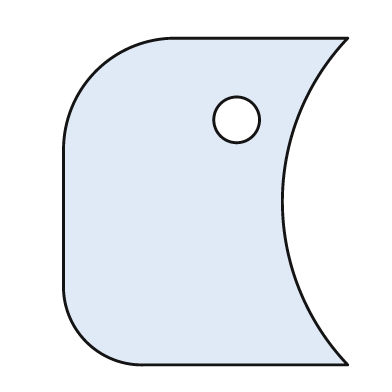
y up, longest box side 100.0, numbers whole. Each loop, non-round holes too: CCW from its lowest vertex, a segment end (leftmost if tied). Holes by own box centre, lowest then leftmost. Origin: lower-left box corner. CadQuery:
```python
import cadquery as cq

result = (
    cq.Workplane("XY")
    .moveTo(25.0, 0.0)
    .lineTo(87.0, 0.0)
    .threePointArc((67.0, 50.0), (87.0, 100.0))
    .lineTo(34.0, 100.0)
    .threePointArc((10.0, 90.0), (0.0, 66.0))
    .lineTo(0.0, 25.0)
    .threePointArc((7.0, 7.0), (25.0, 0.0))
    .close()
    .moveTo(53.0, 75.0)
    .circle(7.0)
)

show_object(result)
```